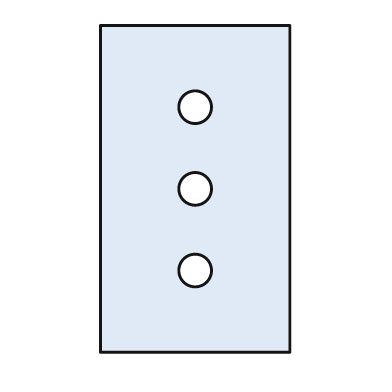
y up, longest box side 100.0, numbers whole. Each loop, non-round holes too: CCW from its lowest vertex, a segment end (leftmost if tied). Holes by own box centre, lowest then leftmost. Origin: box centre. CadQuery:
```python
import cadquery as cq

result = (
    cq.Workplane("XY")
    .moveTo(-29.0, -50.0)
    .lineTo(29.0, -50.0)
    .lineTo(29.0, 50.0)
    .lineTo(-29.0, 50.0)
    .close()
    .moveTo(0.0, -25.0)
    .circle(5.0)
    .moveTo(0.0, 0.0)
    .circle(5.0)
    .moveTo(0.0, 25.0)
    .circle(5.0)
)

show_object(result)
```